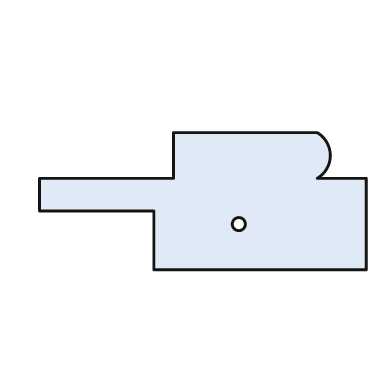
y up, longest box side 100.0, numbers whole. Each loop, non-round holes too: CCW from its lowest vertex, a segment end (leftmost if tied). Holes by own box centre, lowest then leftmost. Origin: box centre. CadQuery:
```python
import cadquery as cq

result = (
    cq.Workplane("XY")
    .moveTo(-15.0, -21.0)
    .lineTo(50.0, -21.0)
    .lineTo(50.0, 7.0)
    .lineTo(35.0, 7.0)
    .threePointArc((39.0, 14.0), (35.0, 21.0))
    .lineTo(-9.0, 21.0)
    .lineTo(-9.0, 7.0)
    .lineTo(-50.0, 7.0)
    .lineTo(-50.0, -3.0)
    .lineTo(-15.0, -3.0)
    .close()
    .moveTo(11.0, -7.0)
    .circle(2.0)
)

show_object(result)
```